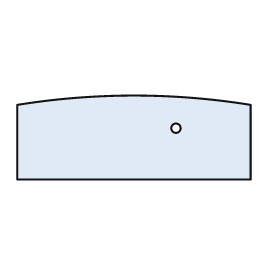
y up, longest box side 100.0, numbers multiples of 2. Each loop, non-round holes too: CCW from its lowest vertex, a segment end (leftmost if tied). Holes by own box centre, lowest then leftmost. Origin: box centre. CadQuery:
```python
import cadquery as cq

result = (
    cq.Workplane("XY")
    .moveTo(-50.0, -18.0)
    .lineTo(50.0, -18.0)
    .lineTo(50.0, 14.0)
    .threePointArc((0.0, 18.0), (-50.0, 14.0))
    .close()
    .moveTo(18.0, 4.0)
    .circle(2.0)
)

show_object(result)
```